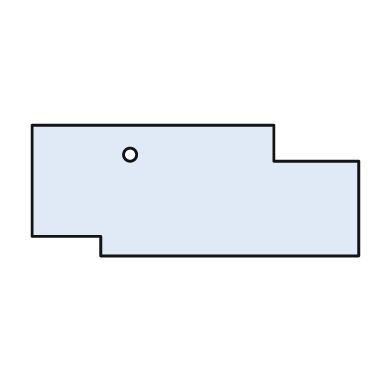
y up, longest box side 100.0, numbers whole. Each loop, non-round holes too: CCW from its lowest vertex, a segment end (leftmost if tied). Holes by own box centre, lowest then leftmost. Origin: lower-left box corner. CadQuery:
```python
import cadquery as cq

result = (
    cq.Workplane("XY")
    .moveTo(21.0, 0.0)
    .lineTo(100.0, 0.0)
    .lineTo(100.0, 29.0)
    .lineTo(74.0, 29.0)
    .lineTo(74.0, 40.0)
    .lineTo(0.0, 40.0)
    .lineTo(0.0, 6.0)
    .lineTo(21.0, 6.0)
    .close()
    .moveTo(30.0, 31.0)
    .circle(2.0)
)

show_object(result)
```